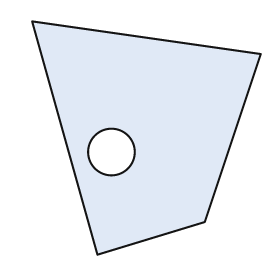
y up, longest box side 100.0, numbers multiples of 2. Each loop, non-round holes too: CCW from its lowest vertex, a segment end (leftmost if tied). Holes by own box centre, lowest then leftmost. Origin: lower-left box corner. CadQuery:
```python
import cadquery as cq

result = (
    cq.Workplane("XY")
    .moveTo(28.0, 0.0)
    .lineTo(74.0, 14.0)
    .lineTo(98.0, 86.0)
    .lineTo(0.0, 100.0)
    .close()
    .moveTo(34.0, 44.0)
    .circle(10.0)
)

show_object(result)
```